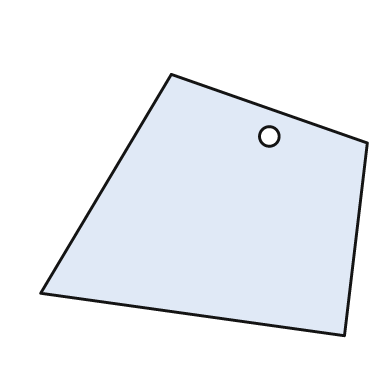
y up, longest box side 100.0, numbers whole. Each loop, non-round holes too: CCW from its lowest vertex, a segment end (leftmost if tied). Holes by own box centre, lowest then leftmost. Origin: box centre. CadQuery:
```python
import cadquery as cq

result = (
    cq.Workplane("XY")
    .moveTo(43.0, -40.0)
    .lineTo(50.0, 19.0)
    .lineTo(-10.0, 40.0)
    .lineTo(-50.0, -27.0)
    .close()
    .moveTo(20.0, 21.0)
    .circle(3.0)
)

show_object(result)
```